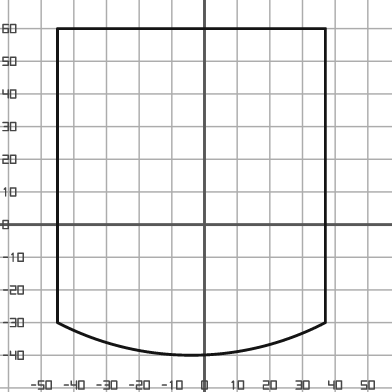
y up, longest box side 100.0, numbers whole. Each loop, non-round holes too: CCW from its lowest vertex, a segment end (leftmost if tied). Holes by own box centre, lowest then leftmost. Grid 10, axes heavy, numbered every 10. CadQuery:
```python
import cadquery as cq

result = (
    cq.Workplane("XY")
    .moveTo(-45.0, -30.0)
    .threePointArc((-4.0, -40.0), (37.0, -30.0))
    .lineTo(37.0, 60.0)
    .lineTo(-45.0, 60.0)
    .close()
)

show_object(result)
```